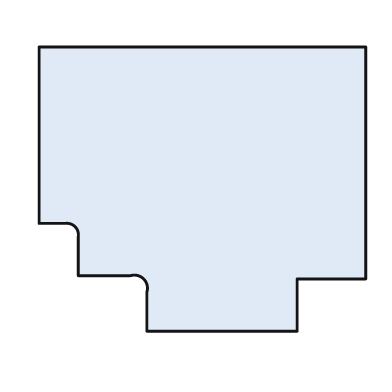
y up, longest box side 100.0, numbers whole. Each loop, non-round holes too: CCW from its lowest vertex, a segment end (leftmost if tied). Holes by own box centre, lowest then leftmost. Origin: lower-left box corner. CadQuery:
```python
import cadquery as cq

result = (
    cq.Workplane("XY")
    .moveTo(33.0, 0.0)
    .lineTo(79.0, 0.0)
    .lineTo(79.0, 16.0)
    .lineTo(100.0, 16.0)
    .lineTo(100.0, 87.0)
    .lineTo(0.0, 87.0)
    .lineTo(0.0, 33.0)
    .lineTo(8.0, 33.0)
    .threePointArc((11.0, 32.0), (12.0, 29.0))
    .lineTo(12.0, 17.0)
    .lineTo(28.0, 17.0)
    .threePointArc((32.0, 16.0), (33.0, 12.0))
    .close()
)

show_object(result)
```